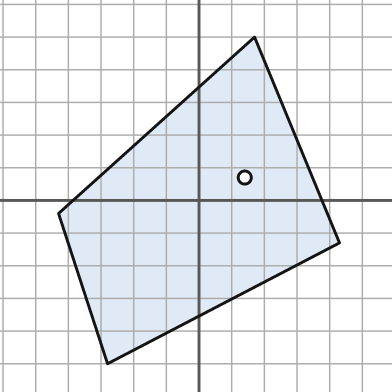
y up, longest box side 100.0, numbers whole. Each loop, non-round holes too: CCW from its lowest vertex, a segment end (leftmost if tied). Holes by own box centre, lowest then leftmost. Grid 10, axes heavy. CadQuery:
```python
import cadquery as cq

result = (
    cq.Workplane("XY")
    .moveTo(-28.0, -50.0)
    .lineTo(43.0, -13.0)
    .lineTo(17.0, 50.0)
    .lineTo(-43.0, -4.0)
    .close()
    .moveTo(14.0, 7.0)
    .circle(2.0)
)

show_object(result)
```